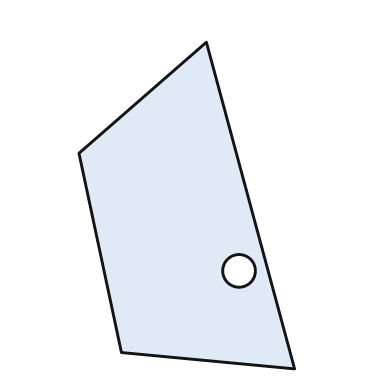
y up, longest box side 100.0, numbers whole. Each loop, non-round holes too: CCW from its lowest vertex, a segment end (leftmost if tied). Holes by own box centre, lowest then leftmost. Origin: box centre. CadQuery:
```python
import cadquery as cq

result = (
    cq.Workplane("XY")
    .moveTo(33.0, -50.0)
    .lineTo(6.0, 50.0)
    .lineTo(-33.0, 16.0)
    .lineTo(-20.0, -45.0)
    .close()
    .moveTo(16.0, -20.0)
    .circle(5.0)
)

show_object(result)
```